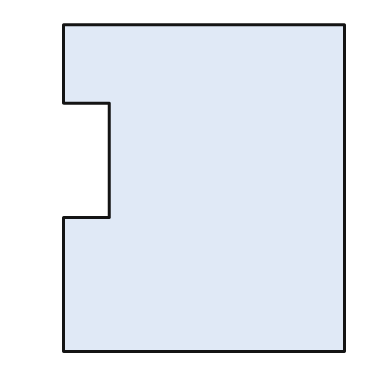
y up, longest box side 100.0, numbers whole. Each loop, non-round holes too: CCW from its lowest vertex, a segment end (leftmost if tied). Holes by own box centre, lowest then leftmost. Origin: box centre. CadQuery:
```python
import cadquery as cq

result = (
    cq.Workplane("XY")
    .moveTo(-43.0, -50.0)
    .lineTo(43.0, -50.0)
    .lineTo(43.0, 50.0)
    .lineTo(-43.0, 50.0)
    .lineTo(-43.0, 26.0)
    .lineTo(-29.0, 26.0)
    .lineTo(-29.0, -9.0)
    .lineTo(-43.0, -9.0)
    .close()
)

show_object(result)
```